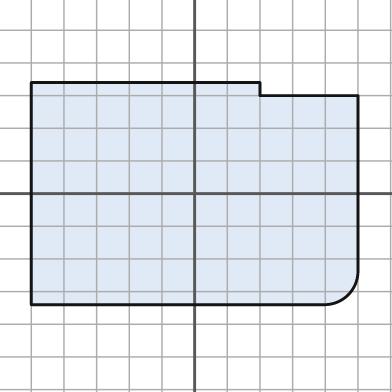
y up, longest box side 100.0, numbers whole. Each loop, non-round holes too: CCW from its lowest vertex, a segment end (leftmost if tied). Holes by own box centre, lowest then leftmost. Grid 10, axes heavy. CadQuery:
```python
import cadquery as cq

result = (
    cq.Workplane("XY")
    .moveTo(-50.0, -34.0)
    .lineTo(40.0, -34.0)
    .threePointArc((47.0, -31.0), (50.0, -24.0))
    .lineTo(50.0, 30.0)
    .lineTo(20.0, 30.0)
    .lineTo(20.0, 34.0)
    .lineTo(-50.0, 34.0)
    .close()
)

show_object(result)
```